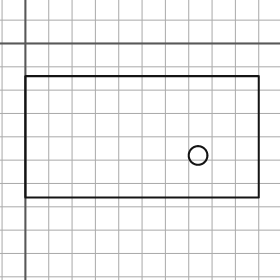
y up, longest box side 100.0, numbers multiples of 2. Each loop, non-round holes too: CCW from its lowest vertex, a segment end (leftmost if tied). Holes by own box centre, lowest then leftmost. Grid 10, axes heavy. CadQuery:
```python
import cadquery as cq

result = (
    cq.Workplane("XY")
    .moveTo(0.0, -66.0)
    .lineTo(100.0, -66.0)
    .lineTo(100.0, -14.0)
    .lineTo(0.0, -14.0)
    .close()
    .moveTo(74.0, -48.0)
    .circle(4.0)
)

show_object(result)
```